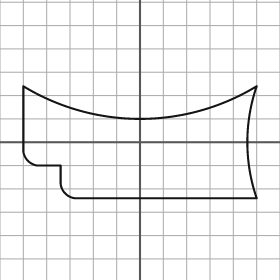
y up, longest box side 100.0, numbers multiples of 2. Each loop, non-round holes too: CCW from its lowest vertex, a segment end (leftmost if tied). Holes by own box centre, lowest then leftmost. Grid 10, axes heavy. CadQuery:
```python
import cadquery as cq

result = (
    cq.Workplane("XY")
    .moveTo(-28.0, -24.0)
    .lineTo(50.0, -24.0)
    .threePointArc((46.0, 0.0), (50.0, 24.0))
    .threePointArc((0.0, 10.0), (-50.0, 24.0))
    .lineTo(-50.0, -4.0)
    .threePointArc((-48.0, -8.0), (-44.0, -10.0))
    .lineTo(-34.0, -10.0)
    .lineTo(-34.0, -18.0)
    .threePointArc((-32.0, -22.0), (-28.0, -24.0))
    .close()
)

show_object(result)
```